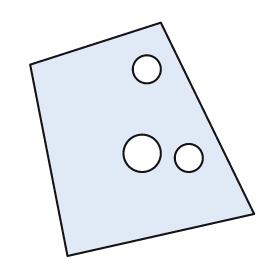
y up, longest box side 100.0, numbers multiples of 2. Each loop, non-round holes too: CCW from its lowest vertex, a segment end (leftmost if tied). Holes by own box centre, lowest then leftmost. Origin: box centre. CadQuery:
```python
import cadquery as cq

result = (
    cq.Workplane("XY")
    .moveTo(-32.0, -50.0)
    .lineTo(48.0, -32.0)
    .lineTo(8.0, 50.0)
    .lineTo(-48.0, 32.0)
    .close()
    .moveTo(20.0, -8.0)
    .circle(6.0)
    .moveTo(0.0, -6.0)
    .circle(8.0)
    .moveTo(2.0, 30.0)
    .circle(6.0)
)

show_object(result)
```